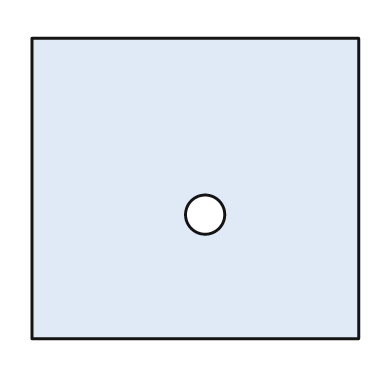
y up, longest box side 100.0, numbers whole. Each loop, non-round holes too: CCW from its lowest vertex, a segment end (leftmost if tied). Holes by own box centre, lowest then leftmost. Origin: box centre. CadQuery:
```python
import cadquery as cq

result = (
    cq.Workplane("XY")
    .moveTo(-50.0, -46.0)
    .lineTo(50.0, -46.0)
    .lineTo(50.0, 46.0)
    .lineTo(-50.0, 46.0)
    .close()
    .moveTo(3.0, -8.0)
    .circle(6.0)
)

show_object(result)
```